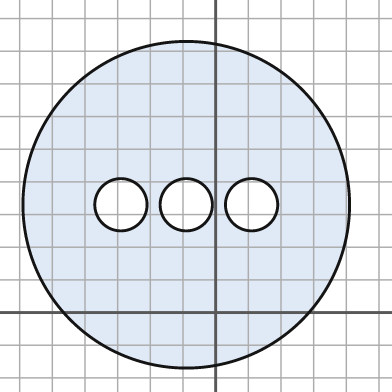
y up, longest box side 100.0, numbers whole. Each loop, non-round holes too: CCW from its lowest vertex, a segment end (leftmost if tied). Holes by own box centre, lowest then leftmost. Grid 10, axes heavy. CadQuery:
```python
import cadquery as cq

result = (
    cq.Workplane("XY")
    .moveTo(-9.0, 33.0)
    .circle(50.0)
    .moveTo(-29.0, 33.0)
    .circle(8.0)
    .moveTo(-9.0, 33.0)
    .circle(8.0)
    .moveTo(11.0, 33.0)
    .circle(8.0)
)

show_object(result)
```